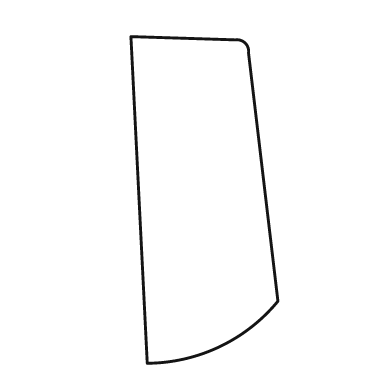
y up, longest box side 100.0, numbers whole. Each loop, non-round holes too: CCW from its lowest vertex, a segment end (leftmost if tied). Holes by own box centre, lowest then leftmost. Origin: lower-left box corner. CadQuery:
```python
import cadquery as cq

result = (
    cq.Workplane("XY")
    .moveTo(5.0, 0.0)
    .threePointArc((27.0, 5.0), (45.0, 19.0))
    .lineTo(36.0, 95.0)
    .threePointArc((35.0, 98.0), (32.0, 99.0))
    .lineTo(0.0, 100.0)
    .close()
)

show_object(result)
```